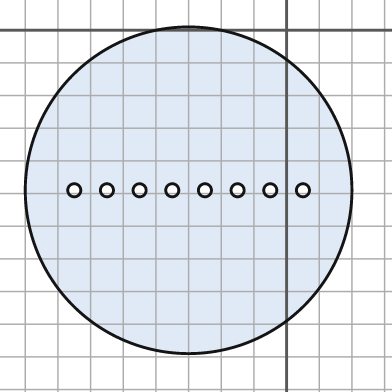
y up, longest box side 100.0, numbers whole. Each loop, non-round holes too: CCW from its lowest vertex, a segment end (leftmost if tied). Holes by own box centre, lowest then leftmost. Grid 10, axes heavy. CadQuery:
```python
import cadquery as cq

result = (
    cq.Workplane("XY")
    .moveTo(-30.0, -49.0)
    .circle(50.0)
    .moveTo(-65.0, -49.0)
    .circle(2.0)
    .moveTo(-55.0, -49.0)
    .circle(2.0)
    .moveTo(-45.0, -49.0)
    .circle(2.0)
    .moveTo(-35.0, -49.0)
    .circle(2.0)
    .moveTo(-25.0, -49.0)
    .circle(2.0)
    .moveTo(-15.0, -49.0)
    .circle(2.0)
    .moveTo(-5.0, -49.0)
    .circle(2.0)
    .moveTo(5.0, -49.0)
    .circle(2.0)
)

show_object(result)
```